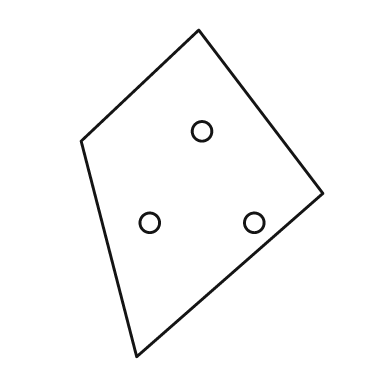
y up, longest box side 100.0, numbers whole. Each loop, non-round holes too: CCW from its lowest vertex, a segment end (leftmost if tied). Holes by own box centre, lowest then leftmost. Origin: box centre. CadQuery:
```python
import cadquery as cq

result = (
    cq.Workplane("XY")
    .moveTo(-20.0, -50.0)
    .lineTo(37.0, 0.0)
    .lineTo(-1.0, 50.0)
    .lineTo(-37.0, 16.0)
    .close()
    .moveTo(-16.0, -9.0)
    .circle(3.0)
    .moveTo(16.0, -9.0)
    .circle(3.0)
    .moveTo(0.0, 19.0)
    .circle(3.0)
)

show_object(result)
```